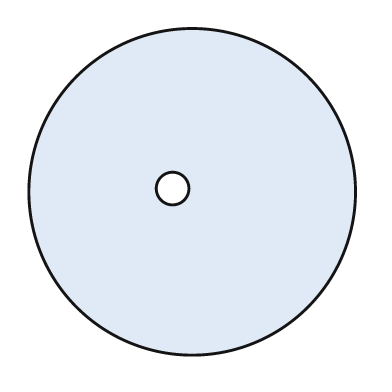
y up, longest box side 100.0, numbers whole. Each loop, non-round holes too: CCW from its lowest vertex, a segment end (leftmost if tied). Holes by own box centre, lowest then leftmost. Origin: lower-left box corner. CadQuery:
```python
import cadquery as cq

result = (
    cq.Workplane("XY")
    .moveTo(50.0, 50.0)
    .circle(50.0)
    .moveTo(44.0, 51.0)
    .circle(5.0)
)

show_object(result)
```